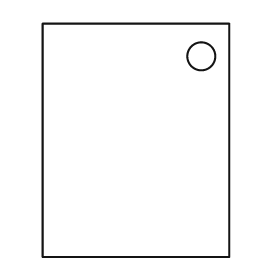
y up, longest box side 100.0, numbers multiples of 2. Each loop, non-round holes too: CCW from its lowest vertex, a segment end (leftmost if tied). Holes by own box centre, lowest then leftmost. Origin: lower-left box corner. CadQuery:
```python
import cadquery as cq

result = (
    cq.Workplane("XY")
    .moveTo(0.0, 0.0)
    .lineTo(80.0, 0.0)
    .lineTo(80.0, 100.0)
    .lineTo(0.0, 100.0)
    .close()
    .moveTo(68.0, 86.0)
    .circle(6.0)
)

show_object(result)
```